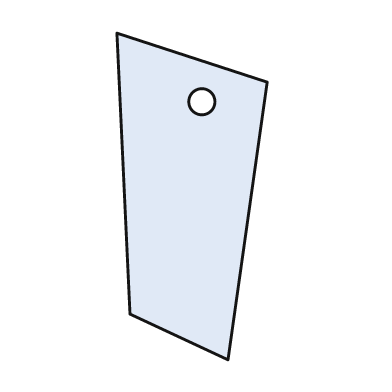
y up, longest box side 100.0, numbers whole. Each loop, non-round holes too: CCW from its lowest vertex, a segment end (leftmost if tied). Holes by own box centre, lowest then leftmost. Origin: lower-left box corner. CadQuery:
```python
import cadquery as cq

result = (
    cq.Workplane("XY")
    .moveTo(34.0, 0.0)
    .lineTo(46.0, 85.0)
    .lineTo(0.0, 100.0)
    .lineTo(4.0, 14.0)
    .close()
    .moveTo(26.0, 79.0)
    .circle(4.0)
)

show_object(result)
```